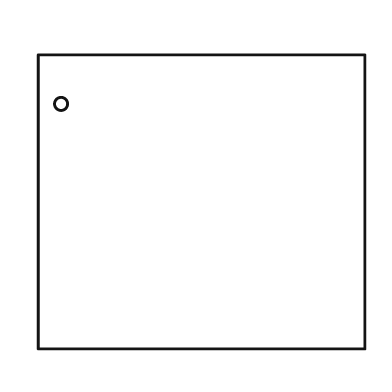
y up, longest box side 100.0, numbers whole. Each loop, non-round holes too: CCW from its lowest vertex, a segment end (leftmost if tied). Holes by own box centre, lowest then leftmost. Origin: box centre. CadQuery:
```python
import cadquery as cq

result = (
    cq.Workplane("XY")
    .moveTo(-50.0, -45.0)
    .lineTo(50.0, -45.0)
    .lineTo(50.0, 45.0)
    .lineTo(-50.0, 45.0)
    .close()
    .moveTo(-43.0, 30.0)
    .circle(2.0)
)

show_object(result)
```